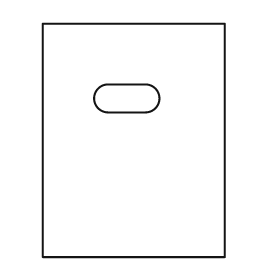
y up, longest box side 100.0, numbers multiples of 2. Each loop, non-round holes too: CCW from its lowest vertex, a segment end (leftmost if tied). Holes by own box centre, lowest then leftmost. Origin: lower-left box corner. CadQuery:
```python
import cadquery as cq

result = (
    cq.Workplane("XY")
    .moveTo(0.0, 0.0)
    .lineTo(78.0, 0.0)
    .lineTo(78.0, 100.0)
    .lineTo(0.0, 100.0)
    .close()
    .moveTo(28.0, 62.0)
    .lineTo(44.0, 62.0)
    .threePointArc((50.0, 68.0), (44.0, 74.0))
    .lineTo(28.0, 74.0)
    .threePointArc((22.0, 68.0), (28.0, 62.0))
    .close()
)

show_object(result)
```